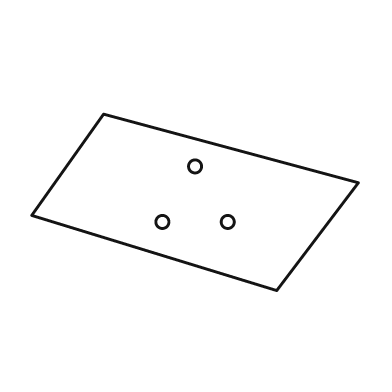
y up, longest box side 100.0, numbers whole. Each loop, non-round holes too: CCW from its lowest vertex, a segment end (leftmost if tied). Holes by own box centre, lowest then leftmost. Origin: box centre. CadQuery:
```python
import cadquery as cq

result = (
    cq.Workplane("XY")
    .moveTo(25.0, -27.0)
    .lineTo(50.0, 6.0)
    .lineTo(-28.0, 27.0)
    .lineTo(-50.0, -4.0)
    .close()
    .moveTo(-10.0, -6.0)
    .circle(2.0)
    .moveTo(10.0, -6.0)
    .circle(2.0)
    .moveTo(0.0, 11.0)
    .circle(2.0)
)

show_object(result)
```